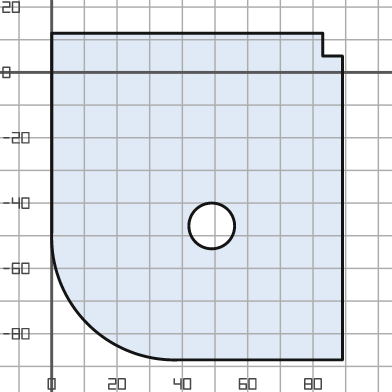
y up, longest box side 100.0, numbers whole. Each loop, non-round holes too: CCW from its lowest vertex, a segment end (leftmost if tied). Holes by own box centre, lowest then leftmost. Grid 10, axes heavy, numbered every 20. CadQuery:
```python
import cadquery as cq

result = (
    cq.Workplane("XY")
    .moveTo(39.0, -88.0)
    .lineTo(89.0, -88.0)
    .lineTo(89.0, 5.0)
    .lineTo(83.0, 5.0)
    .lineTo(83.0, 12.0)
    .lineTo(0.0, 12.0)
    .lineTo(0.0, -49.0)
    .threePointArc((11.0, -77.0), (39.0, -88.0))
    .close()
    .moveTo(49.0, -47.0)
    .circle(7.0)
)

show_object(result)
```